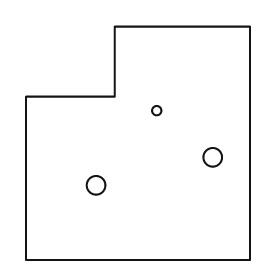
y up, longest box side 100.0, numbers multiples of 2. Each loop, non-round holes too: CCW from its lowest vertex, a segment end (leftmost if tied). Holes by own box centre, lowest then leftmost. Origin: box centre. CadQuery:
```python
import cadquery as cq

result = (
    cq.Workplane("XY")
    .moveTo(-48.0, -50.0)
    .lineTo(48.0, -50.0)
    .lineTo(48.0, 50.0)
    .lineTo(-10.0, 50.0)
    .lineTo(-10.0, 20.0)
    .lineTo(-48.0, 20.0)
    .close()
    .moveTo(-18.0, -18.0)
    .circle(4.0)
    .moveTo(32.0, -6.0)
    .circle(4.0)
    .moveTo(8.0, 14.0)
    .circle(2.0)
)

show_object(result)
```